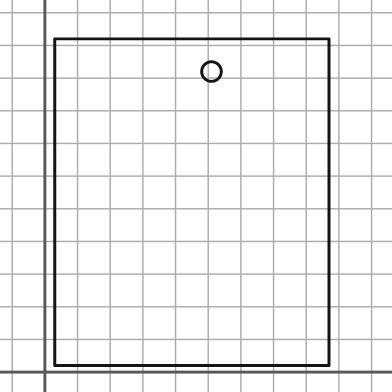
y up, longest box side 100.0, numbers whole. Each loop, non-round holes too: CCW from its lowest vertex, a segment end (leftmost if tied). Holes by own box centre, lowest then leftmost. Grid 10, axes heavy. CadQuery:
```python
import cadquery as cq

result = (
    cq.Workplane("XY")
    .moveTo(3.0, 2.0)
    .lineTo(87.0, 2.0)
    .lineTo(87.0, 102.0)
    .lineTo(3.0, 102.0)
    .close()
    .moveTo(51.0, 92.0)
    .circle(3.0)
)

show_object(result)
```